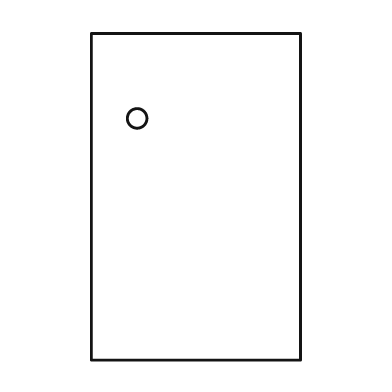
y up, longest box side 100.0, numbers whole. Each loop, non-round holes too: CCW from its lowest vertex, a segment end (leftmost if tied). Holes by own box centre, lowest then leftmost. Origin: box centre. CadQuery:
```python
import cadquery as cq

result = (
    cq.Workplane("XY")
    .moveTo(-32.0, -50.0)
    .lineTo(32.0, -50.0)
    .lineTo(32.0, 50.0)
    .lineTo(-32.0, 50.0)
    .close()
    .moveTo(-18.0, 24.0)
    .circle(3.0)
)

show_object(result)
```